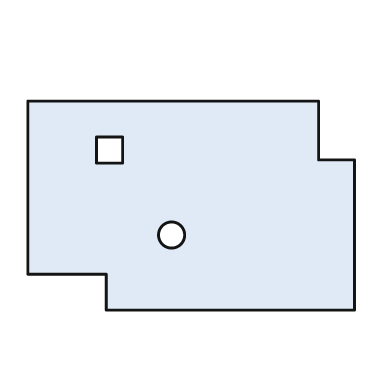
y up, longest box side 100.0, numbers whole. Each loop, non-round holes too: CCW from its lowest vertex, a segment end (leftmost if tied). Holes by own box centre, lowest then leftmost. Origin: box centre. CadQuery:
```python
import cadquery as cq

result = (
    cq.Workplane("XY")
    .moveTo(-26.0, -32.0)
    .lineTo(50.0, -32.0)
    .lineTo(50.0, 14.0)
    .lineTo(39.0, 14.0)
    .lineTo(39.0, 32.0)
    .lineTo(-50.0, 32.0)
    .lineTo(-50.0, -21.0)
    .lineTo(-26.0, -21.0)
    .close()
    .moveTo(-6.0, -9.0)
    .circle(4.0)
    .moveTo(-29.0, 13.0)
    .lineTo(-21.0, 13.0)
    .lineTo(-21.0, 21.0)
    .lineTo(-29.0, 21.0)
    .close()
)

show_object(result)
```